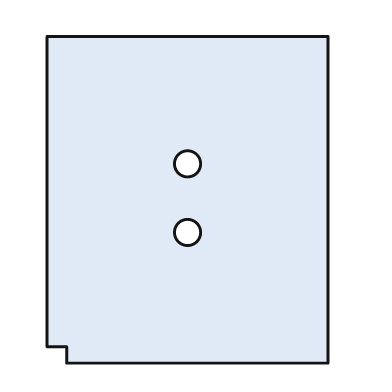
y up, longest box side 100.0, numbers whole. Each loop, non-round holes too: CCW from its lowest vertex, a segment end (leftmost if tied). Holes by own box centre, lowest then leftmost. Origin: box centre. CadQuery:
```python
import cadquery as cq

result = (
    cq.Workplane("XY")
    .moveTo(-37.0, -50.0)
    .lineTo(43.0, -50.0)
    .lineTo(43.0, 50.0)
    .lineTo(-43.0, 50.0)
    .lineTo(-43.0, -45.0)
    .lineTo(-37.0, -45.0)
    .close()
    .moveTo(0.0, -10.0)
    .circle(4.0)
    .moveTo(0.0, 11.0)
    .circle(4.0)
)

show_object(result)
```